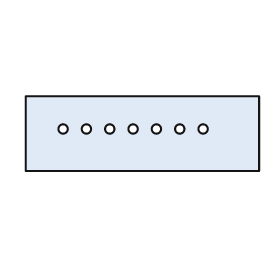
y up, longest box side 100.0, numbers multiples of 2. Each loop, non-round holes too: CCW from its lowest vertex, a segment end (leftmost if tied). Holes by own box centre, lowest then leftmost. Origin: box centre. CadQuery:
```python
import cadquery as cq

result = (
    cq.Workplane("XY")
    .moveTo(-50.0, -16.0)
    .lineTo(50.0, -16.0)
    .lineTo(50.0, 16.0)
    .lineTo(-50.0, 16.0)
    .close()
    .moveTo(-34.0, 2.0)
    .circle(2.0)
    .moveTo(-24.0, 2.0)
    .circle(2.0)
    .moveTo(-14.0, 2.0)
    .circle(2.0)
    .moveTo(-4.0, 2.0)
    .circle(2.0)
    .moveTo(6.0, 2.0)
    .circle(2.0)
    .moveTo(16.0, 2.0)
    .circle(2.0)
    .moveTo(26.0, 2.0)
    .circle(2.0)
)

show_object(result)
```